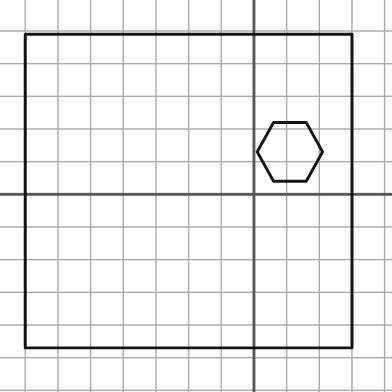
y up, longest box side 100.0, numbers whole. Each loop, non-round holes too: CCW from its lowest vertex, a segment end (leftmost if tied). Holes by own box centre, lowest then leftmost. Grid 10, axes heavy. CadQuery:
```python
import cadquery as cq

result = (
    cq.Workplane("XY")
    .moveTo(-70.0, -47.0)
    .lineTo(30.0, -47.0)
    .lineTo(30.0, 49.0)
    .lineTo(-70.0, 49.0)
    .close()
    .moveTo(6.0, 4.0)
    .lineTo(16.0, 4.0)
    .lineTo(21.0, 13.0)
    .lineTo(16.0, 22.0)
    .lineTo(6.0, 22.0)
    .lineTo(1.0, 13.0)
    .close()
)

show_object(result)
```